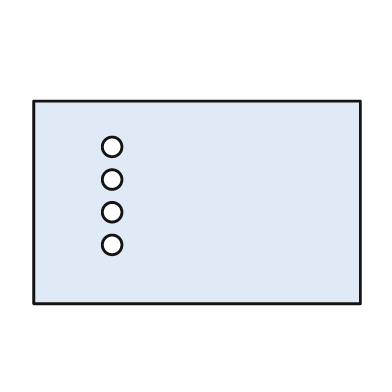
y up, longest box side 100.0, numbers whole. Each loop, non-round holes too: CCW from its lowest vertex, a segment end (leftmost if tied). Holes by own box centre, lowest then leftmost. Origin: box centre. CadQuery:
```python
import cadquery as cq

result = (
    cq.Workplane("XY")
    .moveTo(-50.0, -31.0)
    .lineTo(50.0, -31.0)
    .lineTo(50.0, 31.0)
    .lineTo(-50.0, 31.0)
    .close()
    .moveTo(-26.0, -13.0)
    .circle(3.0)
    .moveTo(-26.0, -3.0)
    .circle(3.0)
    .moveTo(-26.0, 7.0)
    .circle(3.0)
    .moveTo(-26.0, 17.0)
    .circle(3.0)
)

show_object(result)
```